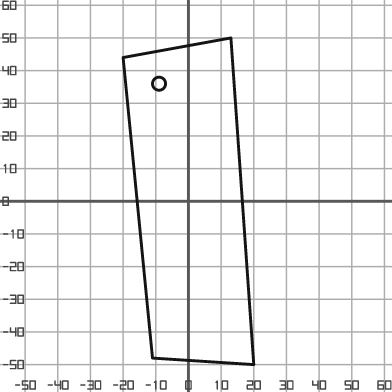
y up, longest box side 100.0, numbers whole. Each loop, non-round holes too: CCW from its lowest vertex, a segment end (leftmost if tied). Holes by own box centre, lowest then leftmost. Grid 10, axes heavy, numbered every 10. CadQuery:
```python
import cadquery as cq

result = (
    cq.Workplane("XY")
    .moveTo(20.0, -50.0)
    .lineTo(13.0, 50.0)
    .lineTo(-20.0, 44.0)
    .lineTo(-11.0, -48.0)
    .close()
    .moveTo(-9.0, 36.0)
    .circle(2.0)
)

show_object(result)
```